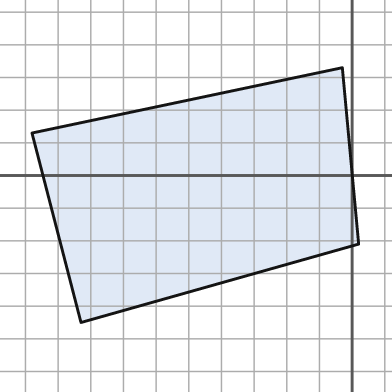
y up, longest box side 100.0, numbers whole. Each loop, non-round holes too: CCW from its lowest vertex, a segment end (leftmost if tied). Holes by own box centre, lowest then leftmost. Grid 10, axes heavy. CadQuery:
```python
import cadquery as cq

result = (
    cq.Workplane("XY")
    .moveTo(-83.0, -45.0)
    .lineTo(2.0, -21.0)
    .lineTo(-3.0, 33.0)
    .lineTo(-98.0, 13.0)
    .close()
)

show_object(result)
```